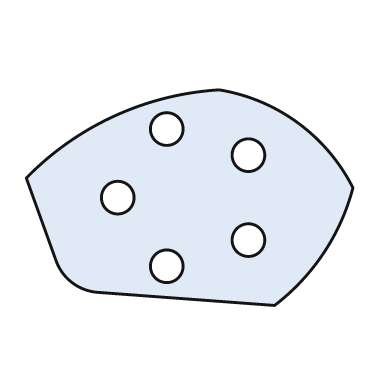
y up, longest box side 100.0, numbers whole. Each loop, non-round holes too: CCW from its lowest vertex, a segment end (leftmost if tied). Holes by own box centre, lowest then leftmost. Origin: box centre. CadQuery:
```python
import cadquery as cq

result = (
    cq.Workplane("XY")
    .moveTo(26.0, -33.0)
    .threePointArc((41.0, -17.0), (50.0, 3.0))
    .threePointArc((33.0, 23.0), (9.0, 33.0))
    .threePointArc((-23.0, 25.0), (-50.0, 6.0))
    .lineTo(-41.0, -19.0)
    .threePointArc((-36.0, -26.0), (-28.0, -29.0))
    .close()
    .moveTo(-7.0, -21.0)
    .circle(5.0)
    .moveTo(18.0, -13.0)
    .circle(5.0)
    .moveTo(-22.0, 0.0)
    .circle(5.0)
    .moveTo(18.0, 13.0)
    .circle(5.0)
    .moveTo(-7.0, 21.0)
    .circle(5.0)
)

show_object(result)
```